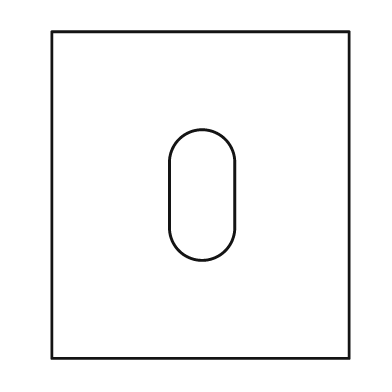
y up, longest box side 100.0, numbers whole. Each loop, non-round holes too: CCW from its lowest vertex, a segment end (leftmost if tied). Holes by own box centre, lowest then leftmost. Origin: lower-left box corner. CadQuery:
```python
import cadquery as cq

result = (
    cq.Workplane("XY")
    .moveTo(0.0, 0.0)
    .lineTo(91.0, 0.0)
    .lineTo(91.0, 100.0)
    .lineTo(0.0, 100.0)
    .close()
    .moveTo(36.0, 40.0)
    .threePointArc((46.0, 30.0), (56.0, 40.0))
    .lineTo(56.0, 60.0)
    .threePointArc((46.0, 70.0), (36.0, 60.0))
    .close()
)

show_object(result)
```